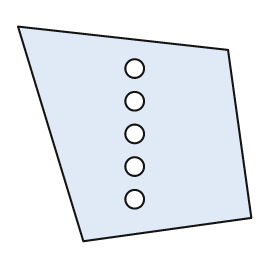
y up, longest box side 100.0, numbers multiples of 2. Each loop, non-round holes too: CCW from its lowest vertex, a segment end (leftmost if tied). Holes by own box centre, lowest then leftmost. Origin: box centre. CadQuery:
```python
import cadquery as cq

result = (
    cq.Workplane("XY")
    .moveTo(-22.0, -46.0)
    .lineTo(50.0, -36.0)
    .lineTo(40.0, 36.0)
    .lineTo(-50.0, 46.0)
    .close()
    .moveTo(0.0, -28.0)
    .circle(4.0)
    .moveTo(0.0, -14.0)
    .circle(4.0)
    .moveTo(0.0, 0.0)
    .circle(4.0)
    .moveTo(0.0, 14.0)
    .circle(4.0)
    .moveTo(0.0, 28.0)
    .circle(4.0)
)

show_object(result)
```